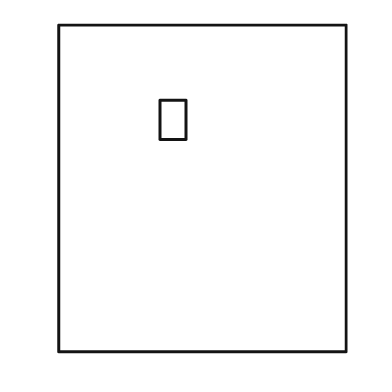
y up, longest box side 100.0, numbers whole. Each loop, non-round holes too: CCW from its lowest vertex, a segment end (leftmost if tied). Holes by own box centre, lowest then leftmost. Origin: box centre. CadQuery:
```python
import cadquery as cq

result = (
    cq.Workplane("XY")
    .moveTo(-44.0, -50.0)
    .lineTo(44.0, -50.0)
    .lineTo(44.0, 50.0)
    .lineTo(-44.0, 50.0)
    .close()
    .moveTo(-13.0, 15.0)
    .lineTo(-5.0, 15.0)
    .lineTo(-5.0, 27.0)
    .lineTo(-13.0, 27.0)
    .close()
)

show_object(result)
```